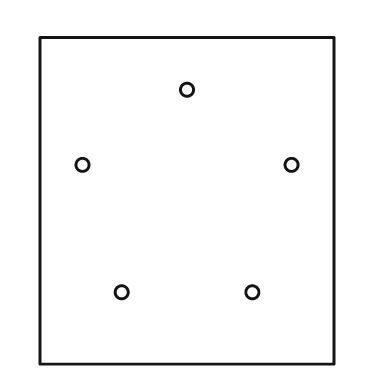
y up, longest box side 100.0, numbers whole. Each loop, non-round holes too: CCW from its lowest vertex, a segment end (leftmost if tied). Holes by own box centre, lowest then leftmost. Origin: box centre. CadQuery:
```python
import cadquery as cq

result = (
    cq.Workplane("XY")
    .moveTo(-45.0, -50.0)
    .lineTo(45.0, -50.0)
    .lineTo(45.0, 50.0)
    .lineTo(-45.0, 50.0)
    .close()
    .moveTo(-20.0, -28.0)
    .circle(2.0)
    .moveTo(20.0, -28.0)
    .circle(2.0)
    .moveTo(-32.0, 11.0)
    .circle(2.0)
    .moveTo(32.0, 11.0)
    .circle(2.0)
    .moveTo(0.0, 34.0)
    .circle(2.0)
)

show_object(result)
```